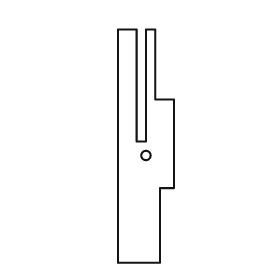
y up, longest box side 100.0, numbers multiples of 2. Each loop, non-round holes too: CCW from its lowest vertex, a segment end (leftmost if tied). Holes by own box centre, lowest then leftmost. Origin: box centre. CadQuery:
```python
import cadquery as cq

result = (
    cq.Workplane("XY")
    .moveTo(-12.0, -50.0)
    .lineTo(6.0, -50.0)
    .lineTo(6.0, -18.0)
    .lineTo(12.0, -18.0)
    .lineTo(12.0, 20.0)
    .lineTo(4.0, 20.0)
    .lineTo(4.0, 50.0)
    .lineTo(0.0, 50.0)
    .lineTo(0.0, 2.0)
    .lineTo(-4.0, 2.0)
    .lineTo(-4.0, 50.0)
    .lineTo(-12.0, 50.0)
    .close()
    .moveTo(0.0, -4.0)
    .circle(2.0)
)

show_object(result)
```